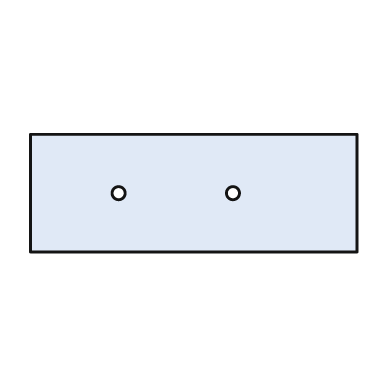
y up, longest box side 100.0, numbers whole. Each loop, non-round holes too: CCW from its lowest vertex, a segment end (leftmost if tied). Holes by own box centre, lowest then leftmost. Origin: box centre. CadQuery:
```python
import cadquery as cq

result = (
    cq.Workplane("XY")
    .moveTo(-50.0, -18.0)
    .lineTo(50.0, -18.0)
    .lineTo(50.0, 18.0)
    .lineTo(-50.0, 18.0)
    .close()
    .moveTo(-23.0, 0.0)
    .circle(2.0)
    .moveTo(12.0, 0.0)
    .circle(2.0)
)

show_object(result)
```